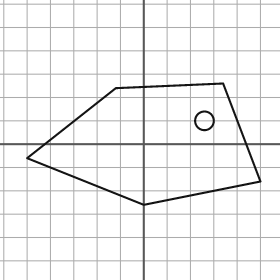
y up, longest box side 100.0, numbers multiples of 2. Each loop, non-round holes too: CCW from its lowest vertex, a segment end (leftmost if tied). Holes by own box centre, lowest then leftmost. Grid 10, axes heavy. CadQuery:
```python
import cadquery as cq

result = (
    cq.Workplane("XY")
    .moveTo(0.0, -26.0)
    .lineTo(50.0, -16.0)
    .lineTo(34.0, 26.0)
    .lineTo(-12.0, 24.0)
    .lineTo(-50.0, -6.0)
    .close()
    .moveTo(26.0, 10.0)
    .circle(4.0)
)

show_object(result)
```